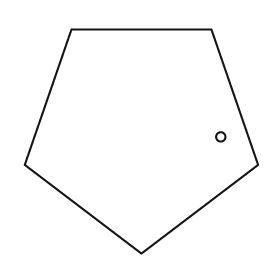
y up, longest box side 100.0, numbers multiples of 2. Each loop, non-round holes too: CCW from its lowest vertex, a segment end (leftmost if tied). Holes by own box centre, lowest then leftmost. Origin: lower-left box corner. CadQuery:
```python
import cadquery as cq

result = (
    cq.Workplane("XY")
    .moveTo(50.0, 0.0)
    .lineTo(100.0, 38.0)
    .lineTo(80.0, 96.0)
    .lineTo(20.0, 96.0)
    .lineTo(0.0, 38.0)
    .close()
    .moveTo(84.0, 50.0)
    .circle(2.0)
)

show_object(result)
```